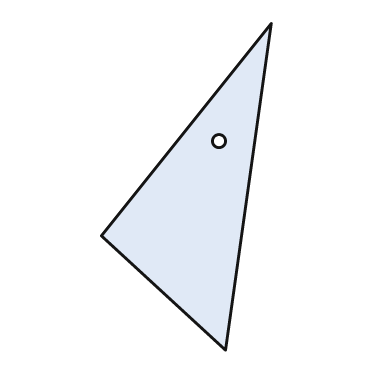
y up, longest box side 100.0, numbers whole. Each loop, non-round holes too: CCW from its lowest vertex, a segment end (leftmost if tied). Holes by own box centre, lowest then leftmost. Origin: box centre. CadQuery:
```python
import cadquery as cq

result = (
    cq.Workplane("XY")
    .moveTo(12.0, -50.0)
    .lineTo(26.0, 50.0)
    .lineTo(-26.0, -15.0)
    .close()
    .moveTo(10.0, 14.0)
    .circle(2.0)
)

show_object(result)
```